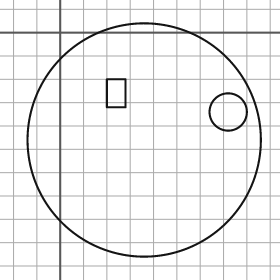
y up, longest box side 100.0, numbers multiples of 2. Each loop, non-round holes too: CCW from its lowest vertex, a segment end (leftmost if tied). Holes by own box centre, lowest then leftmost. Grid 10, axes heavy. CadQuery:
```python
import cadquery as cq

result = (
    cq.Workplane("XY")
    .moveTo(36.0, -46.0)
    .circle(50.0)
    .moveTo(72.0, -34.0)
    .circle(8.0)
    .moveTo(20.0, -32.0)
    .lineTo(28.0, -32.0)
    .lineTo(28.0, -20.0)
    .lineTo(20.0, -20.0)
    .close()
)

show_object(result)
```